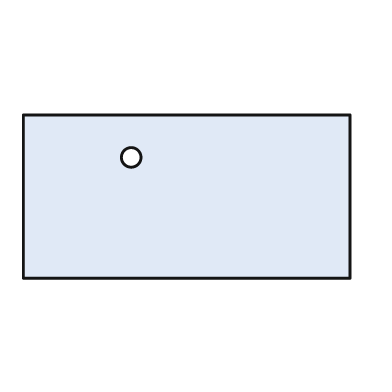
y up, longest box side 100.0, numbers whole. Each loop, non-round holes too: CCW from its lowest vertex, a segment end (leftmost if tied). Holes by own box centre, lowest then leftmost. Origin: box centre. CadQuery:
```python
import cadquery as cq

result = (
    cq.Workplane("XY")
    .moveTo(-50.0, -25.0)
    .lineTo(50.0, -25.0)
    .lineTo(50.0, 25.0)
    .lineTo(-50.0, 25.0)
    .close()
    .moveTo(-17.0, 12.0)
    .circle(3.0)
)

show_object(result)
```